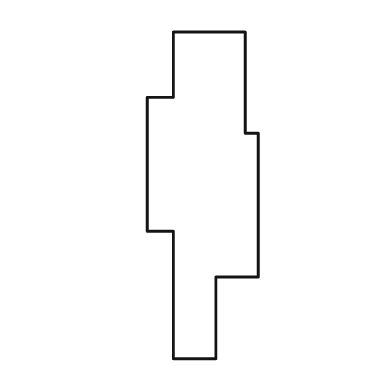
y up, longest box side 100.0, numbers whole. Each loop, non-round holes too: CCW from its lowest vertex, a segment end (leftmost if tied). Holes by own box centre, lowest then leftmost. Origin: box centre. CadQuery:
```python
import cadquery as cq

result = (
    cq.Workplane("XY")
    .moveTo(-9.0, -50.0)
    .lineTo(4.0, -50.0)
    .lineTo(4.0, -25.0)
    .lineTo(17.0, -25.0)
    .lineTo(17.0, 19.0)
    .lineTo(13.0, 19.0)
    .lineTo(13.0, 50.0)
    .lineTo(-9.0, 50.0)
    .lineTo(-9.0, 30.0)
    .lineTo(-17.0, 30.0)
    .lineTo(-17.0, -11.0)
    .lineTo(-9.0, -11.0)
    .close()
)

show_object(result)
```